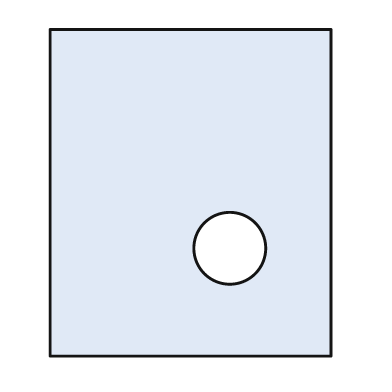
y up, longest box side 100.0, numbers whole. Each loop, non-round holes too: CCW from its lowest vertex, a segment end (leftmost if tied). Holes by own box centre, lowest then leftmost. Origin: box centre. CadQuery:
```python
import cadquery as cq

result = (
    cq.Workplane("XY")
    .moveTo(-43.0, -50.0)
    .lineTo(43.0, -50.0)
    .lineTo(43.0, 50.0)
    .lineTo(-43.0, 50.0)
    .close()
    .moveTo(12.0, -17.0)
    .circle(11.0)
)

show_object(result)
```